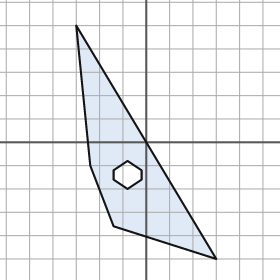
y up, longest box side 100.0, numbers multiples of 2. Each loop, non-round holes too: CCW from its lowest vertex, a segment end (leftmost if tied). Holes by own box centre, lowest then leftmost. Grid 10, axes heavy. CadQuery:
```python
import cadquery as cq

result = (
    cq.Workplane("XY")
    .moveTo(30.0, -50.0)
    .lineTo(-30.0, 50.0)
    .lineTo(-24.0, -10.0)
    .lineTo(-14.0, -36.0)
    .close()
    .moveTo(-8.0, -20.0)
    .lineTo(-2.0, -16.0)
    .lineTo(-2.0, -12.0)
    .lineTo(-8.0, -8.0)
    .lineTo(-14.0, -12.0)
    .lineTo(-14.0, -16.0)
    .close()
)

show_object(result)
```